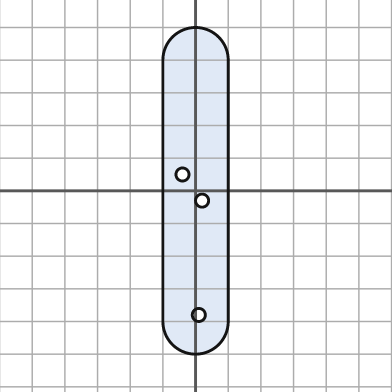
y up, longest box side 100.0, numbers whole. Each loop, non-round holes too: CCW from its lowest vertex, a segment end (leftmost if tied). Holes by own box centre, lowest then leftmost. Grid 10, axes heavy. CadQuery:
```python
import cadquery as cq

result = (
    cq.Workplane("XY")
    .moveTo(-10.0, -40.0)
    .threePointArc((0.0, -50.0), (10.0, -40.0))
    .lineTo(10.0, 40.0)
    .threePointArc((0.0, 50.0), (-10.0, 40.0))
    .close()
    .moveTo(1.0, -38.0)
    .circle(2.0)
    .moveTo(2.0, -3.0)
    .circle(2.0)
    .moveTo(-4.0, 5.0)
    .circle(2.0)
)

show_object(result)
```